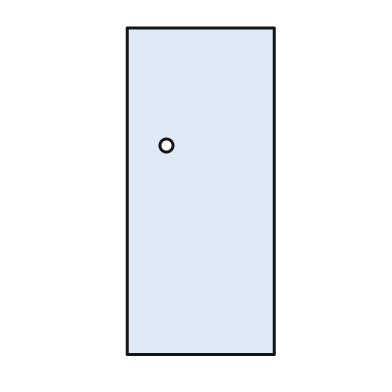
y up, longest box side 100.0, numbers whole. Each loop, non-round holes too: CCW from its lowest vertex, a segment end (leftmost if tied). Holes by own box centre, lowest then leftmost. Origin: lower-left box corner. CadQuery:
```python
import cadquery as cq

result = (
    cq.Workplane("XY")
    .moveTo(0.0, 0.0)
    .lineTo(45.0, 0.0)
    .lineTo(45.0, 100.0)
    .lineTo(0.0, 100.0)
    .close()
    .moveTo(12.0, 64.0)
    .circle(2.0)
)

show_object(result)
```